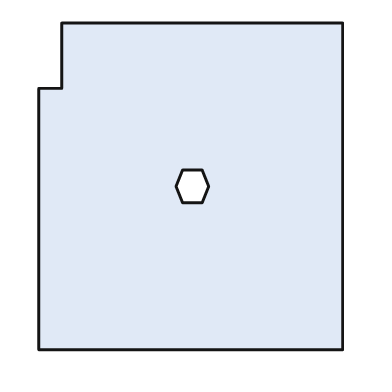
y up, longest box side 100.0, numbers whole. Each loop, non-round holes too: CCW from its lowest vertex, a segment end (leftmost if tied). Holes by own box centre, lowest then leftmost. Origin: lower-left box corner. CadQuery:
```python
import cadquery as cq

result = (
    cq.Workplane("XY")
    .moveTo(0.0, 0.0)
    .lineTo(93.0, 0.0)
    .lineTo(93.0, 100.0)
    .lineTo(7.0, 100.0)
    .lineTo(7.0, 80.0)
    .lineTo(0.0, 80.0)
    .close()
    .moveTo(44.0, 45.0)
    .lineTo(50.0, 45.0)
    .lineTo(52.0, 50.0)
    .lineTo(50.0, 55.0)
    .lineTo(44.0, 55.0)
    .lineTo(42.0, 50.0)
    .close()
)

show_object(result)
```